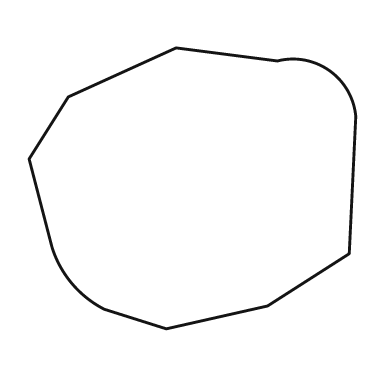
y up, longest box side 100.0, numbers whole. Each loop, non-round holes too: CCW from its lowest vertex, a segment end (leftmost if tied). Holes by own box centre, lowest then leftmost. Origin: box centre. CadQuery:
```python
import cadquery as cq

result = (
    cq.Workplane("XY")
    .moveTo(-8.0, -43.0)
    .lineTo(23.0, -36.0)
    .lineTo(48.0, -20.0)
    .lineTo(50.0, 22.0)
    .threePointArc((42.0, 36.0), (26.0, 39.0))
    .lineTo(-5.0, 43.0)
    .lineTo(-38.0, 28.0)
    .lineTo(-50.0, 9.0)
    .lineTo(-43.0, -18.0)
    .threePointArc((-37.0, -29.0), (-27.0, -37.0))
    .close()
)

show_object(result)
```